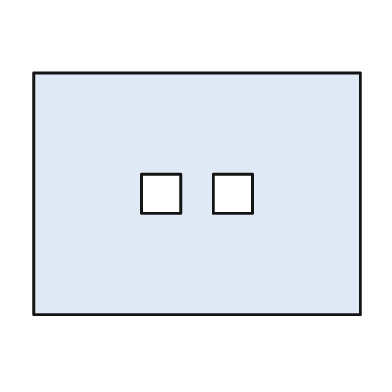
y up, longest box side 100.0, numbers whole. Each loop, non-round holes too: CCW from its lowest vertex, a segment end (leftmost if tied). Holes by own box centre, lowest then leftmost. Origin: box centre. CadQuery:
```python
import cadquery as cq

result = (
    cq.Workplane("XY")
    .moveTo(-50.0, -37.0)
    .lineTo(50.0, -37.0)
    .lineTo(50.0, 37.0)
    .lineTo(-50.0, 37.0)
    .close()
    .moveTo(-17.0, -6.0)
    .lineTo(-5.0, -6.0)
    .lineTo(-5.0, 6.0)
    .lineTo(-17.0, 6.0)
    .close()
    .moveTo(5.0, -6.0)
    .lineTo(17.0, -6.0)
    .lineTo(17.0, 6.0)
    .lineTo(5.0, 6.0)
    .close()
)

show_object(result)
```